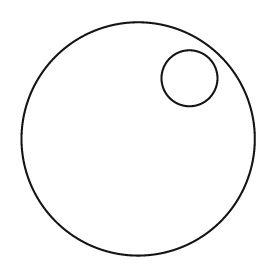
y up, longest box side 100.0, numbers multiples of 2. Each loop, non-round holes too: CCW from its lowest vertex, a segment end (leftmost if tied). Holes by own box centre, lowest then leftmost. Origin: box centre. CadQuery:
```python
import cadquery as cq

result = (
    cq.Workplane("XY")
    .moveTo(0.0, 0.0)
    .circle(50.0)
    .moveTo(22.0, 26.0)
    .circle(12.0)
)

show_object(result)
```